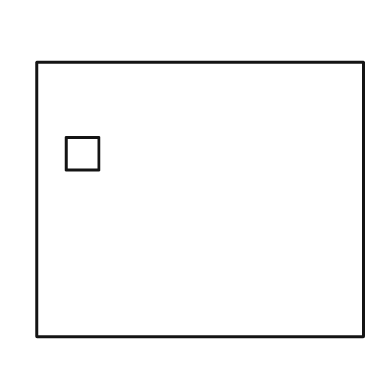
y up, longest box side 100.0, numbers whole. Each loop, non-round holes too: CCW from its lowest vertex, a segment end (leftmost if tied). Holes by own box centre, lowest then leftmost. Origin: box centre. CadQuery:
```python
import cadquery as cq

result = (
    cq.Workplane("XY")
    .moveTo(-50.0, -42.0)
    .lineTo(50.0, -42.0)
    .lineTo(50.0, 42.0)
    .lineTo(-50.0, 42.0)
    .close()
    .moveTo(-41.0, 9.0)
    .lineTo(-31.0, 9.0)
    .lineTo(-31.0, 19.0)
    .lineTo(-41.0, 19.0)
    .close()
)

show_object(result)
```